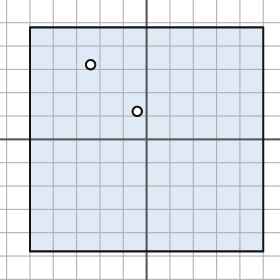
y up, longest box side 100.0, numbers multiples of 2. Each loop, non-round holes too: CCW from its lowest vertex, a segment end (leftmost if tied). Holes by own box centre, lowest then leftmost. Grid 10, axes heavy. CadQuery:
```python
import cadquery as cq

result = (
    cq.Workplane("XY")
    .moveTo(-50.0, -48.0)
    .lineTo(50.0, -48.0)
    .lineTo(50.0, 48.0)
    .lineTo(-50.0, 48.0)
    .close()
    .moveTo(-4.0, 12.0)
    .circle(2.0)
    .moveTo(-24.0, 32.0)
    .circle(2.0)
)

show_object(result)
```